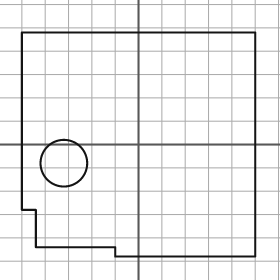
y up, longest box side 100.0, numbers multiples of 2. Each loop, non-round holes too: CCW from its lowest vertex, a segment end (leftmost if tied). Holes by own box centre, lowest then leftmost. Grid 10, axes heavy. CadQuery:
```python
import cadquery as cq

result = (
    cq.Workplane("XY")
    .moveTo(-10.0, -48.0)
    .lineTo(50.0, -48.0)
    .lineTo(50.0, 48.0)
    .lineTo(-50.0, 48.0)
    .lineTo(-50.0, -28.0)
    .lineTo(-44.0, -28.0)
    .lineTo(-44.0, -44.0)
    .lineTo(-10.0, -44.0)
    .close()
    .moveTo(-32.0, -8.0)
    .circle(10.0)
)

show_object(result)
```